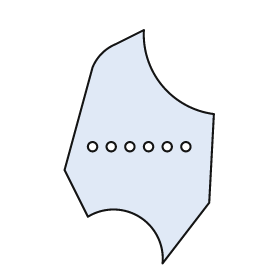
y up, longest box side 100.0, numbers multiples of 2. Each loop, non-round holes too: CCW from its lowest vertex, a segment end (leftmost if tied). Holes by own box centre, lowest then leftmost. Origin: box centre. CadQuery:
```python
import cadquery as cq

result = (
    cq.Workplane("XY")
    .moveTo(10.0, -50.0)
    .lineTo(30.0, -24.0)
    .lineTo(32.0, 14.0)
    .threePointArc((10.0, 26.0), (2.0, 50.0))
    .lineTo(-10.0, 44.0)
    .threePointArc((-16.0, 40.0), (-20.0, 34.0))
    .lineTo(-32.0, -10.0)
    .lineTo(-22.0, -30.0)
    .threePointArc((0.0, -30.0), (10.0, -50.0))
    .close()
    .moveTo(-20.0, 0.0)
    .circle(2.0)
    .moveTo(-12.0, 0.0)
    .circle(2.0)
    .moveTo(-4.0, 0.0)
    .circle(2.0)
    .moveTo(4.0, 0.0)
    .circle(2.0)
    .moveTo(12.0, 0.0)
    .circle(2.0)
    .moveTo(20.0, 0.0)
    .circle(2.0)
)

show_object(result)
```